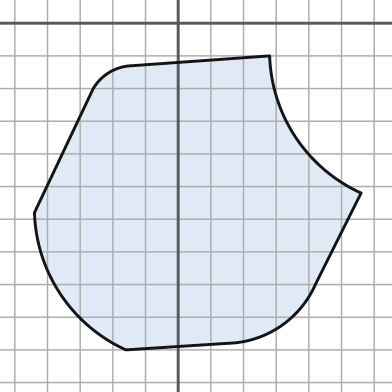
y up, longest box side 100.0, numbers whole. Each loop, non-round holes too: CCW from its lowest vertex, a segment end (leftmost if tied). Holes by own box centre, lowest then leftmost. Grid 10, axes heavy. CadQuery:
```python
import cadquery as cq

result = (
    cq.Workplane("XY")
    .moveTo(-16.0, -100.0)
    .lineTo(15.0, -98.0)
    .threePointArc((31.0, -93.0), (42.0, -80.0))
    .lineTo(56.0, -52.0)
    .threePointArc((36.0, -35.0), (28.0, -10.0))
    .lineTo(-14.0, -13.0)
    .threePointArc((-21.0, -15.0), (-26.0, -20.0))
    .lineTo(-44.0, -58.0)
    .threePointArc((-36.0, -83.0), (-16.0, -100.0))
    .close()
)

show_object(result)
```